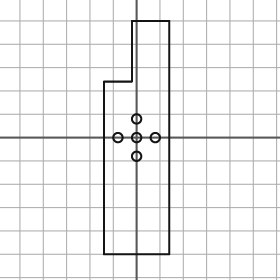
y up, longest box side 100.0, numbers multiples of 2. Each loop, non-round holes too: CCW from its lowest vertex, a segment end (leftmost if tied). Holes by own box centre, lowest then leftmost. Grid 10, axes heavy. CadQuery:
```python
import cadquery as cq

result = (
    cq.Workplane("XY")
    .moveTo(-14.0, -50.0)
    .lineTo(14.0, -50.0)
    .lineTo(14.0, 50.0)
    .lineTo(-2.0, 50.0)
    .lineTo(-2.0, 24.0)
    .lineTo(-14.0, 24.0)
    .close()
    .moveTo(0.0, -8.0)
    .circle(2.0)
    .moveTo(-8.0, 0.0)
    .circle(2.0)
    .moveTo(0.0, 0.0)
    .circle(2.0)
    .moveTo(8.0, 0.0)
    .circle(2.0)
    .moveTo(0.0, 8.0)
    .circle(2.0)
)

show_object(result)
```